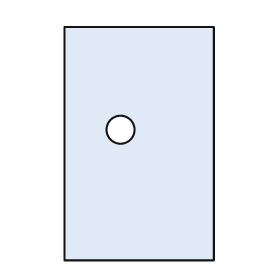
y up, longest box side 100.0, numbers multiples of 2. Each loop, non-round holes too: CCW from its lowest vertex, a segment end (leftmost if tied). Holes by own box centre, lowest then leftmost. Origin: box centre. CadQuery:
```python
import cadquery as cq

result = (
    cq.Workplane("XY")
    .moveTo(-32.0, -50.0)
    .lineTo(32.0, -50.0)
    .lineTo(32.0, 50.0)
    .lineTo(-32.0, 50.0)
    .close()
    .moveTo(-8.0, 6.0)
    .circle(6.0)
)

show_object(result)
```